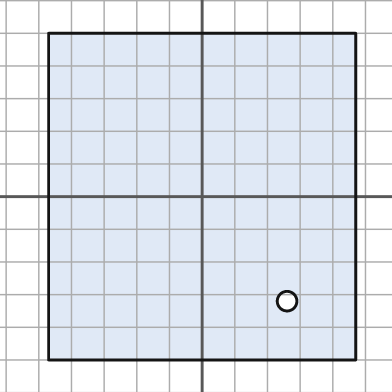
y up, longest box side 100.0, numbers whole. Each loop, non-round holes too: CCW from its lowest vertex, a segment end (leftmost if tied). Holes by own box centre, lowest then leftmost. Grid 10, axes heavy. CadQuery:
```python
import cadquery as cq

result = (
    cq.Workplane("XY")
    .moveTo(-47.0, -50.0)
    .lineTo(47.0, -50.0)
    .lineTo(47.0, 50.0)
    .lineTo(-47.0, 50.0)
    .close()
    .moveTo(26.0, -32.0)
    .circle(3.0)
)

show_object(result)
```